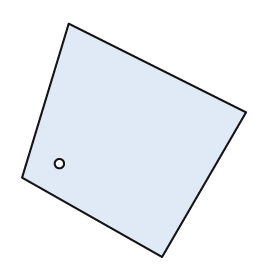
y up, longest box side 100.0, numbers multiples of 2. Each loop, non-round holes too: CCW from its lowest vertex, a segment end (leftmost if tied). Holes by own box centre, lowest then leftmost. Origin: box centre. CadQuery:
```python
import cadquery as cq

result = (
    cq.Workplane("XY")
    .moveTo(12.0, -50.0)
    .lineTo(48.0, 12.0)
    .lineTo(-28.0, 50.0)
    .lineTo(-48.0, -16.0)
    .close()
    .moveTo(-32.0, -10.0)
    .circle(2.0)
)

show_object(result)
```